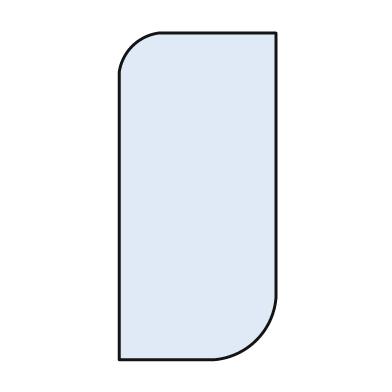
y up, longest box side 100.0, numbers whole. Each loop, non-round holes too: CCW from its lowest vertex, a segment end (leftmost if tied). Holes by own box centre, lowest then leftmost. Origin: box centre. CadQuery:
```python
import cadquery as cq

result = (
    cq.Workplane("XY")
    .moveTo(-24.0, -50.0)
    .lineTo(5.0, -50.0)
    .threePointArc((18.0, -44.0), (24.0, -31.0))
    .lineTo(24.0, 50.0)
    .lineTo(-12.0, 50.0)
    .threePointArc((-20.0, 46.0), (-24.0, 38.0))
    .close()
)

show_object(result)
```